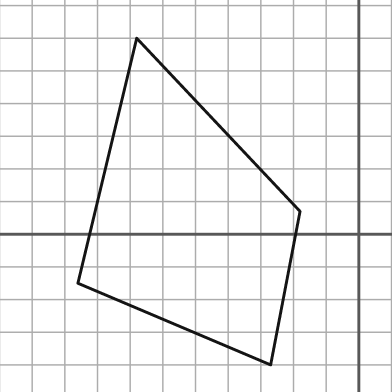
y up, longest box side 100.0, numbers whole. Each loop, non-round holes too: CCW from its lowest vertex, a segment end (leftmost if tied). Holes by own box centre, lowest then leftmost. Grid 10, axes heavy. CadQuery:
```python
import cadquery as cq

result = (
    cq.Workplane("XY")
    .moveTo(-27.0, -40.0)
    .lineTo(-18.0, 7.0)
    .lineTo(-68.0, 60.0)
    .lineTo(-86.0, -15.0)
    .close()
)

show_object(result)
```